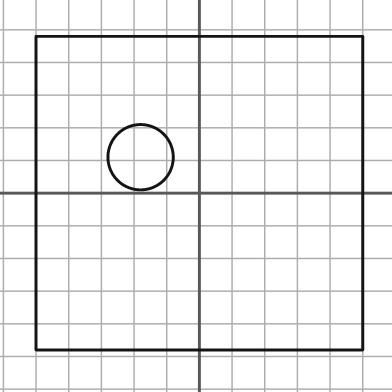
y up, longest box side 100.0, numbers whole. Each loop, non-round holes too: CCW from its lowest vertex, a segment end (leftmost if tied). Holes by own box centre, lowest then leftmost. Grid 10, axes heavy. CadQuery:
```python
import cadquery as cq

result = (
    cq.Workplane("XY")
    .moveTo(-50.0, -48.0)
    .lineTo(50.0, -48.0)
    .lineTo(50.0, 48.0)
    .lineTo(-50.0, 48.0)
    .close()
    .moveTo(-18.0, 11.0)
    .circle(10.0)
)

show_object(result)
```